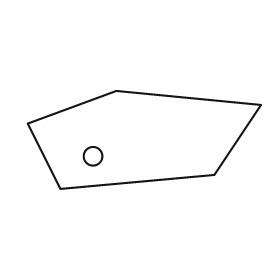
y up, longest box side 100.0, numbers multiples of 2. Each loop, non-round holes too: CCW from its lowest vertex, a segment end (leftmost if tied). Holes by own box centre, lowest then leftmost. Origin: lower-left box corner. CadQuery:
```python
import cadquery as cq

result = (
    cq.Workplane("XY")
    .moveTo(14.0, 0.0)
    .lineTo(80.0, 6.0)
    .lineTo(100.0, 36.0)
    .lineTo(38.0, 42.0)
    .lineTo(0.0, 28.0)
    .close()
    .moveTo(28.0, 14.0)
    .circle(4.0)
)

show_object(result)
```